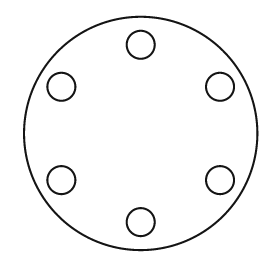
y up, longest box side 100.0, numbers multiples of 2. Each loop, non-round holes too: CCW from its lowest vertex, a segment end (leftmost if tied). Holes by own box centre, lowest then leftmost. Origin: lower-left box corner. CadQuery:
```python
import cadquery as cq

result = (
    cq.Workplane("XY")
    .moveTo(50.0, 50.0)
    .circle(50.0)
    .moveTo(50.0, 12.0)
    .circle(6.0)
    .moveTo(16.0, 30.0)
    .circle(6.0)
    .moveTo(84.0, 30.0)
    .circle(6.0)
    .moveTo(16.0, 70.0)
    .circle(6.0)
    .moveTo(84.0, 70.0)
    .circle(6.0)
    .moveTo(50.0, 88.0)
    .circle(6.0)
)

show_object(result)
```